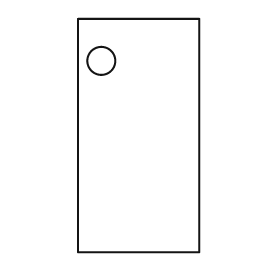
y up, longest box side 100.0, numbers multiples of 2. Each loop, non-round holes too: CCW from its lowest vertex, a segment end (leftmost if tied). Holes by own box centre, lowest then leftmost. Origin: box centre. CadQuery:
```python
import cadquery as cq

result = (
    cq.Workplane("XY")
    .moveTo(-26.0, -50.0)
    .lineTo(26.0, -50.0)
    .lineTo(26.0, 50.0)
    .lineTo(-26.0, 50.0)
    .close()
    .moveTo(-16.0, 32.0)
    .circle(6.0)
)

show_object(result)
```